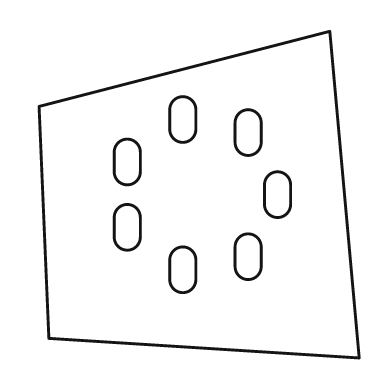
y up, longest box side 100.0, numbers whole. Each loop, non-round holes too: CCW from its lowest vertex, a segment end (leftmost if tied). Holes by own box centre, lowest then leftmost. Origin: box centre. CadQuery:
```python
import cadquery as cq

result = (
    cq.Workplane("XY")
    .moveTo(49.0, -50.0)
    .lineTo(40.0, 50.0)
    .lineTo(-49.0, 27.0)
    .lineTo(-46.0, -44.0)
    .close()
    .moveTo(-9.0, -26.0)
    .threePointArc((-5.0, -30.0), (-1.0, -26.0))
    .lineTo(-1.0, -20.0)
    .threePointArc((-5.0, -16.0), (-9.0, -20.0))
    .close()
    .moveTo(11.0, -22.0)
    .threePointArc((15.0, -26.0), (19.0, -22.0))
    .lineTo(19.0, -16.0)
    .threePointArc((15.0, -12.0), (11.0, -16.0))
    .close()
    .moveTo(-26.0, -13.0)
    .threePointArc((-22.0, -17.0), (-18.0, -13.0))
    .lineTo(-18.0, -7.0)
    .threePointArc((-22.0, -3.0), (-26.0, -7.0))
    .close()
    .moveTo(20.0, -3.0)
    .threePointArc((24.0, -7.0), (28.0, -3.0))
    .lineTo(28.0, 3.0)
    .threePointArc((24.0, 7.0), (20.0, 3.0))
    .close()
    .moveTo(-26.0, 7.0)
    .threePointArc((-22.0, 3.0), (-18.0, 7.0))
    .lineTo(-18.0, 13.0)
    .threePointArc((-22.0, 17.0), (-26.0, 13.0))
    .close()
    .moveTo(11.0, 16.0)
    .threePointArc((15.0, 12.0), (19.0, 16.0))
    .lineTo(19.0, 22.0)
    .threePointArc((15.0, 26.0), (11.0, 22.0))
    .close()
    .moveTo(-9.0, 20.0)
    .threePointArc((-5.0, 16.0), (-1.0, 20.0))
    .lineTo(-1.0, 26.0)
    .threePointArc((-5.0, 30.0), (-9.0, 26.0))
    .close()
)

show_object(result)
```